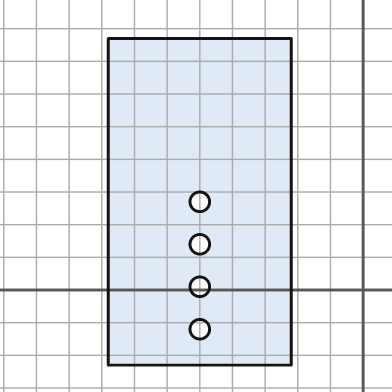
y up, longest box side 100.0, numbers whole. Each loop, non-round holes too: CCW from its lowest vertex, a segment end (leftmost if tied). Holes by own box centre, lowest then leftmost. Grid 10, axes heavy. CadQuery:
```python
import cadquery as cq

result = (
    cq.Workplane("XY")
    .moveTo(-78.0, -23.0)
    .lineTo(-22.0, -23.0)
    .lineTo(-22.0, 77.0)
    .lineTo(-78.0, 77.0)
    .close()
    .moveTo(-50.0, -12.0)
    .circle(3.0)
    .moveTo(-50.0, 1.0)
    .circle(3.0)
    .moveTo(-50.0, 14.0)
    .circle(3.0)
    .moveTo(-50.0, 27.0)
    .circle(3.0)
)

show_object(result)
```